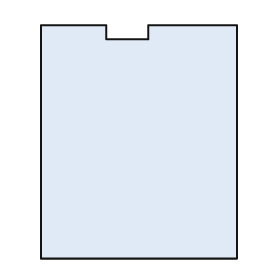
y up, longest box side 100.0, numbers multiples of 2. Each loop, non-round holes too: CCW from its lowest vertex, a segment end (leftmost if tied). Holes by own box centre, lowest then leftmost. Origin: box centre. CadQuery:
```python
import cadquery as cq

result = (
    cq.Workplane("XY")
    .moveTo(-42.0, -50.0)
    .lineTo(42.0, -50.0)
    .lineTo(42.0, 50.0)
    .lineTo(4.0, 50.0)
    .lineTo(4.0, 44.0)
    .lineTo(-14.0, 44.0)
    .lineTo(-14.0, 50.0)
    .lineTo(-42.0, 50.0)
    .close()
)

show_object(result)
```